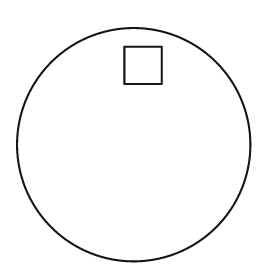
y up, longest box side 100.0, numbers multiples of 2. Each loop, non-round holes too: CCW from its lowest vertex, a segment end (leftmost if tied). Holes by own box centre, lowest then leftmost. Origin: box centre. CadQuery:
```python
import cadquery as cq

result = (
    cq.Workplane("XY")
    .moveTo(0.0, 0.0)
    .circle(50.0)
    .moveTo(-4.0, 26.0)
    .lineTo(12.0, 26.0)
    .lineTo(12.0, 42.0)
    .lineTo(-4.0, 42.0)
    .close()
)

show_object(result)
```